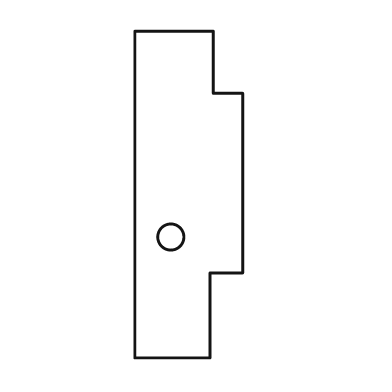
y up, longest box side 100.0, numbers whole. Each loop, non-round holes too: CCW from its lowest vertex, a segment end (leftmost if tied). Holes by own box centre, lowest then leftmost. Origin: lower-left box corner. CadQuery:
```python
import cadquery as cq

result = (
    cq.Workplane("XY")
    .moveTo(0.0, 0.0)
    .lineTo(23.0, 0.0)
    .lineTo(23.0, 26.0)
    .lineTo(33.0, 26.0)
    .lineTo(33.0, 81.0)
    .lineTo(24.0, 81.0)
    .lineTo(24.0, 100.0)
    .lineTo(0.0, 100.0)
    .close()
    .moveTo(11.0, 37.0)
    .circle(4.0)
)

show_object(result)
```